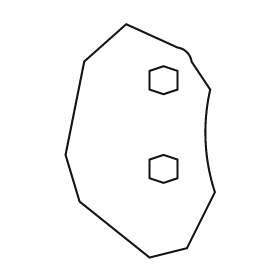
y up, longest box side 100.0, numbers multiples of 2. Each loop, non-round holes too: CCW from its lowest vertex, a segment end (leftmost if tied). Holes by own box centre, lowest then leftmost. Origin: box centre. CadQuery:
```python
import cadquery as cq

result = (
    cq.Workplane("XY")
    .moveTo(4.0, -50.0)
    .lineTo(20.0, -46.0)
    .lineTo(32.0, -22.0)
    .threePointArc((28.0, 0.0), (30.0, 22.0))
    .lineTo(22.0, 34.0)
    .threePointArc((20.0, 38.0), (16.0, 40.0))
    .lineTo(-6.0, 50.0)
    .lineTo(-24.0, 34.0)
    .lineTo(-32.0, -6.0)
    .lineTo(-26.0, -26.0)
    .close()
    .moveTo(10.0, -18.0)
    .lineTo(16.0, -16.0)
    .lineTo(16.0, -8.0)
    .lineTo(10.0, -6.0)
    .lineTo(4.0, -8.0)
    .lineTo(4.0, -16.0)
    .close()
    .moveTo(10.0, 20.0)
    .lineTo(16.0, 22.0)
    .lineTo(16.0, 30.0)
    .lineTo(10.0, 32.0)
    .lineTo(4.0, 30.0)
    .lineTo(4.0, 22.0)
    .close()
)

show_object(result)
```